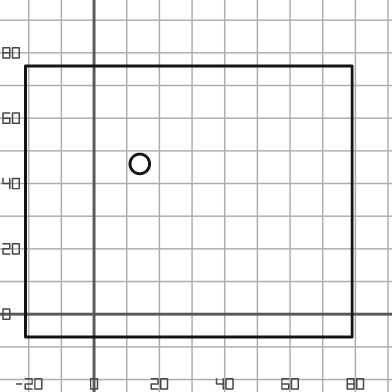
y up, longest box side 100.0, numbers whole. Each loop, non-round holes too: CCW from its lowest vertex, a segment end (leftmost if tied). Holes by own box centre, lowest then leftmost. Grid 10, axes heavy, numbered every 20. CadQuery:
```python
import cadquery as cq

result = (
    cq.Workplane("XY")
    .moveTo(-21.0, -7.0)
    .lineTo(79.0, -7.0)
    .lineTo(79.0, 76.0)
    .lineTo(-21.0, 76.0)
    .close()
    .moveTo(14.0, 46.0)
    .circle(3.0)
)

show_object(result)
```